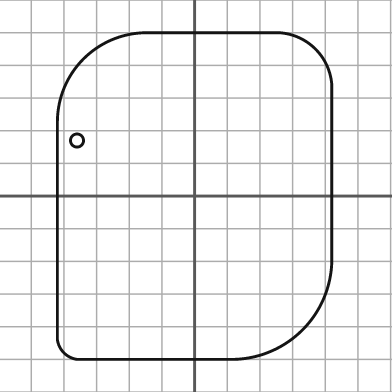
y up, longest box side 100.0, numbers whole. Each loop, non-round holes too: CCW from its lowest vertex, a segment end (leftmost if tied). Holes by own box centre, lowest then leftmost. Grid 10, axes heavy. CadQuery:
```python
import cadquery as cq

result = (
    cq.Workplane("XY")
    .moveTo(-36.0, -50.0)
    .lineTo(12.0, -50.0)
    .threePointArc((33.0, -41.0), (42.0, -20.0))
    .lineTo(42.0, 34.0)
    .threePointArc((37.0, 45.0), (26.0, 50.0))
    .lineTo(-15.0, 50.0)
    .threePointArc((-34.0, 42.0), (-42.0, 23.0))
    .lineTo(-42.0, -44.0)
    .threePointArc((-40.0, -48.0), (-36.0, -50.0))
    .close()
    .moveTo(-36.0, 17.0)
    .circle(2.0)
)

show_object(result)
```